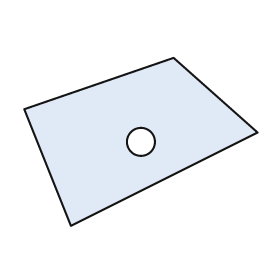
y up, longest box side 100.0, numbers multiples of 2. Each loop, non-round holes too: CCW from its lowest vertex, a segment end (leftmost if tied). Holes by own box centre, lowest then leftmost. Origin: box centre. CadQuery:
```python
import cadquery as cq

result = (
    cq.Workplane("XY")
    .moveTo(-30.0, -36.0)
    .lineTo(50.0, 4.0)
    .lineTo(14.0, 36.0)
    .lineTo(-50.0, 14.0)
    .close()
    .moveTo(0.0, 0.0)
    .circle(6.0)
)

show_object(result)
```